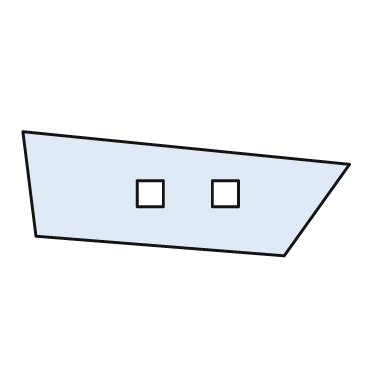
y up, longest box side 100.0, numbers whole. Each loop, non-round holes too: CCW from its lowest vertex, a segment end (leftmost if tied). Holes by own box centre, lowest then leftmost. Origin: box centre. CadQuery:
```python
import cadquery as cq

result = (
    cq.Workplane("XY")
    .moveTo(30.0, -19.0)
    .lineTo(50.0, 9.0)
    .lineTo(-50.0, 19.0)
    .lineTo(-46.0, -13.0)
    .close()
    .moveTo(-15.0, -4.0)
    .lineTo(-7.0, -4.0)
    .lineTo(-7.0, 4.0)
    .lineTo(-15.0, 4.0)
    .close()
    .moveTo(8.0, -4.0)
    .lineTo(16.0, -4.0)
    .lineTo(16.0, 4.0)
    .lineTo(8.0, 4.0)
    .close()
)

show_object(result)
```